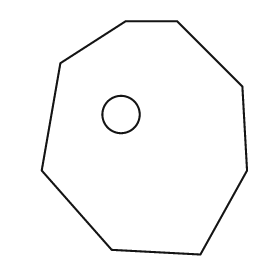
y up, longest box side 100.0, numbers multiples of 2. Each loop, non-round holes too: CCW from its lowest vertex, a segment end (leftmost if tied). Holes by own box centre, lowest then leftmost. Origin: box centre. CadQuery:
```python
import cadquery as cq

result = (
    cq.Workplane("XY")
    .moveTo(24.0, -50.0)
    .lineTo(44.0, -14.0)
    .lineTo(42.0, 22.0)
    .lineTo(14.0, 50.0)
    .lineTo(-8.0, 50.0)
    .lineTo(-36.0, 32.0)
    .lineTo(-44.0, -14.0)
    .lineTo(-14.0, -48.0)
    .close()
    .moveTo(-10.0, 10.0)
    .circle(8.0)
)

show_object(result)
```